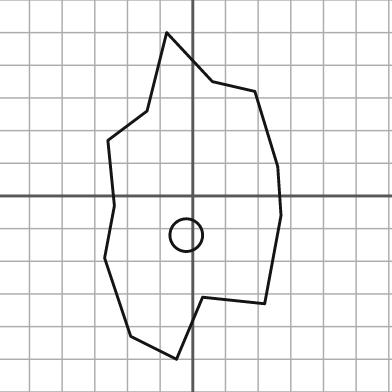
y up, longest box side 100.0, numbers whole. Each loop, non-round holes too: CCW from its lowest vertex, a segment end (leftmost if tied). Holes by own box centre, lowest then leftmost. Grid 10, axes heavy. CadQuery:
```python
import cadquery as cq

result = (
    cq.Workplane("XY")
    .moveTo(-5.0, -50.0)
    .lineTo(3.0, -31.0)
    .lineTo(22.0, -33.0)
    .lineTo(27.0, -6.0)
    .lineTo(26.0, 9.0)
    .lineTo(19.0, 32.0)
    .lineTo(6.0, 35.0)
    .lineTo(-8.0, 50.0)
    .lineTo(-14.0, 26.0)
    .lineTo(-26.0, 17.0)
    .lineTo(-24.0, -3.0)
    .lineTo(-27.0, -19.0)
    .lineTo(-19.0, -43.0)
    .close()
    .moveTo(-2.0, -12.0)
    .circle(5.0)
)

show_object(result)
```